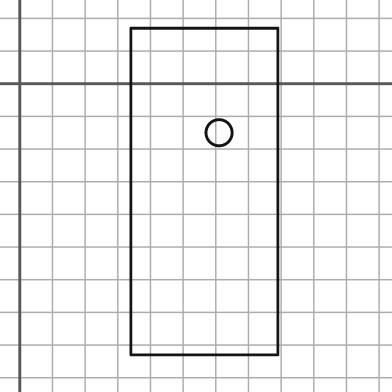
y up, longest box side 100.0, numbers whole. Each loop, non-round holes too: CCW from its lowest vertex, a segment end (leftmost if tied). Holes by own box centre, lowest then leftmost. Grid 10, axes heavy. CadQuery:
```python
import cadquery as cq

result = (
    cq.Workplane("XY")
    .moveTo(34.0, -83.0)
    .lineTo(79.0, -83.0)
    .lineTo(79.0, 17.0)
    .lineTo(34.0, 17.0)
    .close()
    .moveTo(61.0, -15.0)
    .circle(4.0)
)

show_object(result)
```